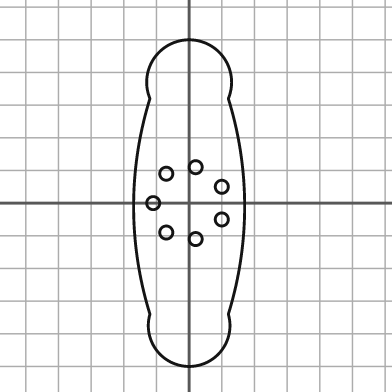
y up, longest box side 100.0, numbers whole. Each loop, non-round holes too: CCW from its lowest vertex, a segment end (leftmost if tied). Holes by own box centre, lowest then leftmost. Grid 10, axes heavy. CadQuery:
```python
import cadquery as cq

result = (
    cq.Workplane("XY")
    .moveTo(-12.0, -34.0)
    .threePointArc((0.0, -50.0), (12.0, -34.0))
    .threePointArc((17.0, -1.0), (12.0, 32.0))
    .threePointArc((0.0, 50.0), (-12.0, 32.0))
    .threePointArc((-17.0, -1.0), (-12.0, -34.0))
    .close()
    .moveTo(2.0, -11.0)
    .circle(2.0)
    .moveTo(-7.0, -9.0)
    .circle(2.0)
    .moveTo(10.0, -5.0)
    .circle(2.0)
    .moveTo(-11.0, 0.0)
    .circle(2.0)
    .moveTo(10.0, 5.0)
    .circle(2.0)
    .moveTo(-7.0, 9.0)
    .circle(2.0)
    .moveTo(2.0, 11.0)
    .circle(2.0)
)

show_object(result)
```